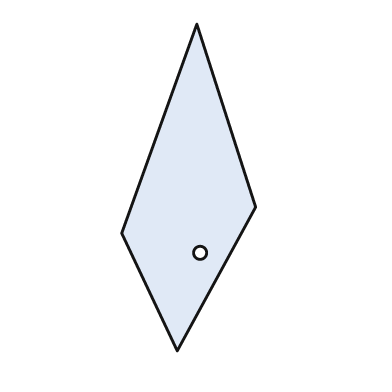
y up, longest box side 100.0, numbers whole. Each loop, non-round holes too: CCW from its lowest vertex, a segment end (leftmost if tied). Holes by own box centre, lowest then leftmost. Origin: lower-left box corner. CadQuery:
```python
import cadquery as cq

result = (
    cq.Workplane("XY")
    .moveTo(17.0, 0.0)
    .lineTo(41.0, 44.0)
    .lineTo(23.0, 100.0)
    .lineTo(0.0, 36.0)
    .close()
    .moveTo(24.0, 30.0)
    .circle(2.0)
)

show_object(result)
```